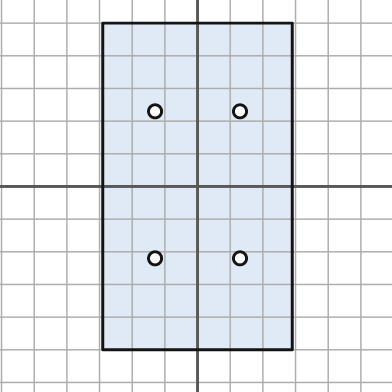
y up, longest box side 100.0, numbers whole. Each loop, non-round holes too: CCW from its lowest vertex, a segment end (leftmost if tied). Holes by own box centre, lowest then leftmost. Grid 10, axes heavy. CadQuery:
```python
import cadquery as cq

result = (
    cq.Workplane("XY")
    .moveTo(-29.0, -50.0)
    .lineTo(29.0, -50.0)
    .lineTo(29.0, 50.0)
    .lineTo(-29.0, 50.0)
    .close()
    .moveTo(-13.0, -22.0)
    .circle(2.0)
    .moveTo(13.0, -22.0)
    .circle(2.0)
    .moveTo(-13.0, 23.0)
    .circle(2.0)
    .moveTo(13.0, 23.0)
    .circle(2.0)
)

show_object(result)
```